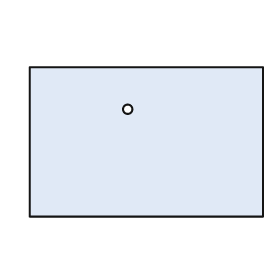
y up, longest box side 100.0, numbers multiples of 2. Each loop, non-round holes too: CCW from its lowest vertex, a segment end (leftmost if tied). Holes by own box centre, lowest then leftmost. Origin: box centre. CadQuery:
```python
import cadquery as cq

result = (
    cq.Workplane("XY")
    .moveTo(-50.0, -32.0)
    .lineTo(50.0, -32.0)
    .lineTo(50.0, 32.0)
    .lineTo(-50.0, 32.0)
    .close()
    .moveTo(-8.0, 14.0)
    .circle(2.0)
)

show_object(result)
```